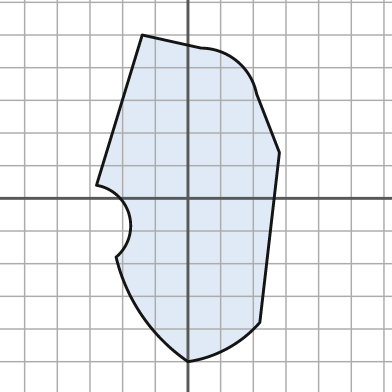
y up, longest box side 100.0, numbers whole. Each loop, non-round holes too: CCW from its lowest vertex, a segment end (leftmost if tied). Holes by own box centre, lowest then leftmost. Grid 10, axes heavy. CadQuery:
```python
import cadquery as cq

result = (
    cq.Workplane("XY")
    .moveTo(0.0, -50.0)
    .threePointArc((12.0, -46.0), (22.0, -38.0))
    .lineTo(28.0, 14.0)
    .lineTo(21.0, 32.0)
    .threePointArc((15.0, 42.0), (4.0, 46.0))
    .lineTo(-14.0, 50.0)
    .lineTo(-28.0, 4.0)
    .threePointArc((-18.0, -5.0), (-22.0, -18.0))
    .threePointArc((-14.0, -36.0), (0.0, -50.0))
    .close()
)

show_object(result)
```